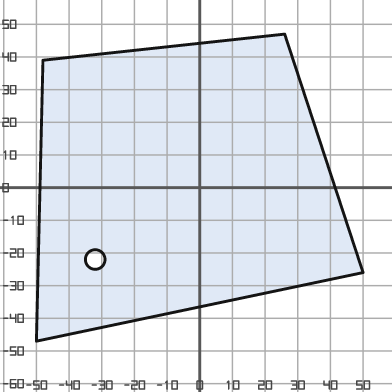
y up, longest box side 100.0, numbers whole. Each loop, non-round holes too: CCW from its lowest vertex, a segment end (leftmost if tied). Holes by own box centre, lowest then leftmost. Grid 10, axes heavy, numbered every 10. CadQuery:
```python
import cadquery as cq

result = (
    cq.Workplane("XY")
    .moveTo(-50.0, -47.0)
    .lineTo(50.0, -26.0)
    .lineTo(26.0, 47.0)
    .lineTo(-48.0, 39.0)
    .close()
    .moveTo(-32.0, -22.0)
    .circle(3.0)
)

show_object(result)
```